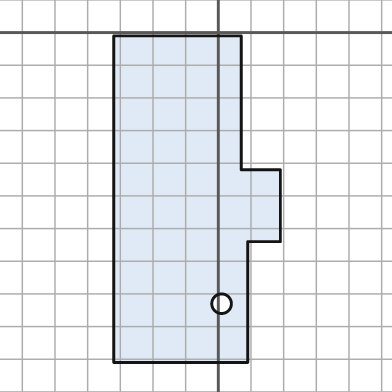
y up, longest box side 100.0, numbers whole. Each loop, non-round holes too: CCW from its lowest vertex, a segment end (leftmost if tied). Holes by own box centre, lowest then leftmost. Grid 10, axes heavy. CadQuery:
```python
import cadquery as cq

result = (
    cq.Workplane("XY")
    .moveTo(-32.0, -101.0)
    .lineTo(9.0, -101.0)
    .lineTo(9.0, -64.0)
    .lineTo(19.0, -64.0)
    .lineTo(19.0, -42.0)
    .lineTo(7.0, -42.0)
    .lineTo(7.0, -1.0)
    .lineTo(-32.0, -1.0)
    .close()
    .moveTo(1.0, -83.0)
    .circle(3.0)
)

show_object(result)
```